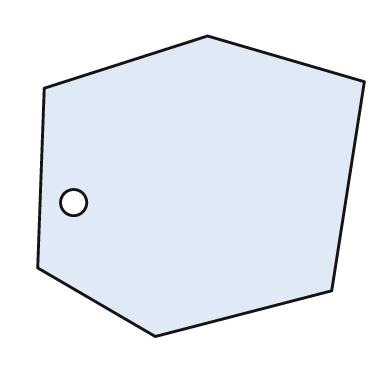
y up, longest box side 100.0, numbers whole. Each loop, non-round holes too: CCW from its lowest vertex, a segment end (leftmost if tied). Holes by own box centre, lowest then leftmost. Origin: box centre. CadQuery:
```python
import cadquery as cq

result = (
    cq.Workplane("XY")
    .moveTo(-14.0, -46.0)
    .lineTo(40.0, -32.0)
    .lineTo(50.0, 32.0)
    .lineTo(2.0, 46.0)
    .lineTo(-48.0, 30.0)
    .lineTo(-50.0, -25.0)
    .close()
    .moveTo(-39.0, -5.0)
    .circle(4.0)
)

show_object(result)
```